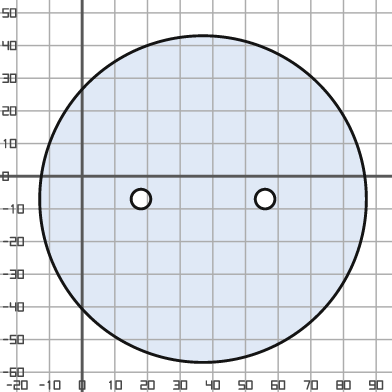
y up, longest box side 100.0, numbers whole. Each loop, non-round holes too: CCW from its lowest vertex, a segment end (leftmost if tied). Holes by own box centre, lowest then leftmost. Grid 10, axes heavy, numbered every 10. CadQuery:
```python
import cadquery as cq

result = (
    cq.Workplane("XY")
    .moveTo(37.0, -7.0)
    .circle(50.0)
    .moveTo(18.0, -7.0)
    .circle(3.0)
    .moveTo(56.0, -7.0)
    .circle(3.0)
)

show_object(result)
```